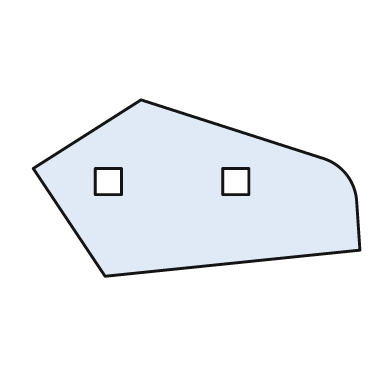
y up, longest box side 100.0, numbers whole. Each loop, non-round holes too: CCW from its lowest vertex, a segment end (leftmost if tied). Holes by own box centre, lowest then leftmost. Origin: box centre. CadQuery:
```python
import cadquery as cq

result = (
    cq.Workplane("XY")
    .moveTo(-28.0, -27.0)
    .lineTo(50.0, -19.0)
    .lineTo(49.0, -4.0)
    .threePointArc((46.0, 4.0), (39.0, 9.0))
    .lineTo(-17.0, 27.0)
    .lineTo(-50.0, 6.0)
    .close()
    .moveTo(-31.0, -2.0)
    .lineTo(-23.0, -2.0)
    .lineTo(-23.0, 6.0)
    .lineTo(-31.0, 6.0)
    .close()
    .moveTo(8.0, -2.0)
    .lineTo(16.0, -2.0)
    .lineTo(16.0, 6.0)
    .lineTo(8.0, 6.0)
    .close()
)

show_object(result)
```